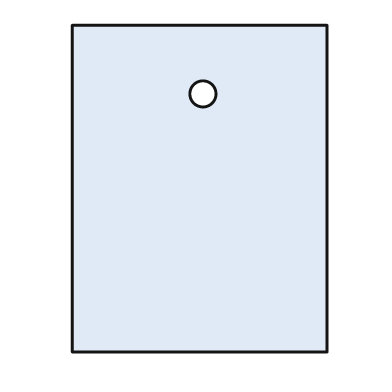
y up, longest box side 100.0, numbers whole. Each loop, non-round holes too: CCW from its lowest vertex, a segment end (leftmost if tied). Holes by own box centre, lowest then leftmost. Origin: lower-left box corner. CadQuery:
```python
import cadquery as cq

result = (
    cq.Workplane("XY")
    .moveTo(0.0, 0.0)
    .lineTo(78.0, 0.0)
    .lineTo(78.0, 100.0)
    .lineTo(0.0, 100.0)
    .close()
    .moveTo(40.0, 79.0)
    .circle(4.0)
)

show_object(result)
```